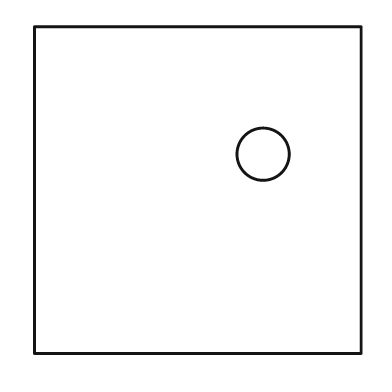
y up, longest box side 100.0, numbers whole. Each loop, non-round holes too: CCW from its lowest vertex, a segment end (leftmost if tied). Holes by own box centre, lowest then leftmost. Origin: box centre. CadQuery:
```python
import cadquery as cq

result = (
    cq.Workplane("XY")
    .moveTo(-50.0, -50.0)
    .lineTo(50.0, -50.0)
    .lineTo(50.0, 50.0)
    .lineTo(-50.0, 50.0)
    .close()
    .moveTo(20.0, 11.0)
    .circle(8.0)
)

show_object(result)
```